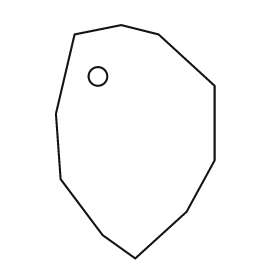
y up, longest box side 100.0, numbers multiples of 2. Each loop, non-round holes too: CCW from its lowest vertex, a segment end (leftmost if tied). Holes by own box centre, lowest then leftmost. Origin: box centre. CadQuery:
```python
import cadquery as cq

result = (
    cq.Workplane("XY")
    .moveTo(0.0, -50.0)
    .lineTo(22.0, -30.0)
    .lineTo(34.0, -8.0)
    .lineTo(34.0, 24.0)
    .lineTo(10.0, 46.0)
    .lineTo(-6.0, 50.0)
    .lineTo(-26.0, 46.0)
    .lineTo(-34.0, 12.0)
    .lineTo(-32.0, -16.0)
    .lineTo(-14.0, -40.0)
    .close()
    .moveTo(-16.0, 28.0)
    .circle(4.0)
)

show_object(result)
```